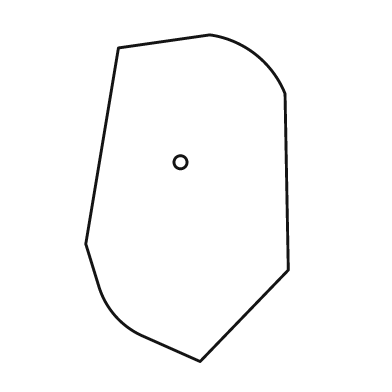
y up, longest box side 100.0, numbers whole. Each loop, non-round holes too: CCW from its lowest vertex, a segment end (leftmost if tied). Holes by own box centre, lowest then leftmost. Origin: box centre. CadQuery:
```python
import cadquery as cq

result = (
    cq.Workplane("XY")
    .moveTo(4.0, -50.0)
    .lineTo(31.0, -22.0)
    .lineTo(30.0, 32.0)
    .threePointArc((21.0, 44.0), (7.0, 50.0))
    .lineTo(-21.0, 46.0)
    .lineTo(-31.0, -14.0)
    .lineTo(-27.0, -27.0)
    .threePointArc((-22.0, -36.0), (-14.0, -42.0))
    .close()
    .moveTo(-2.0, 11.0)
    .circle(2.0)
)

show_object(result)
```